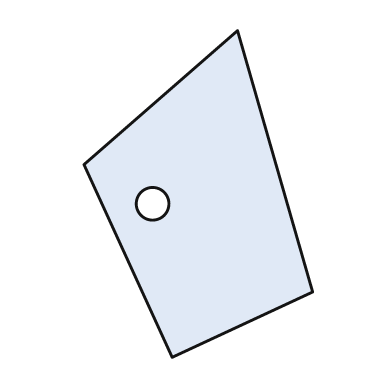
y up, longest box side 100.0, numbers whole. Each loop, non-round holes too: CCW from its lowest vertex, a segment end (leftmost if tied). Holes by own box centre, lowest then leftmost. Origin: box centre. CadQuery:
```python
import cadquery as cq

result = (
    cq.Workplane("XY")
    .moveTo(-8.0, -50.0)
    .lineTo(35.0, -30.0)
    .lineTo(12.0, 50.0)
    .lineTo(-35.0, 9.0)
    .close()
    .moveTo(-14.0, -3.0)
    .circle(5.0)
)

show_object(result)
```